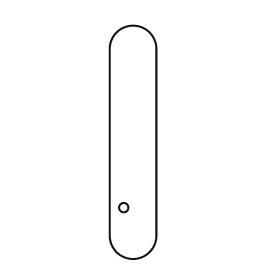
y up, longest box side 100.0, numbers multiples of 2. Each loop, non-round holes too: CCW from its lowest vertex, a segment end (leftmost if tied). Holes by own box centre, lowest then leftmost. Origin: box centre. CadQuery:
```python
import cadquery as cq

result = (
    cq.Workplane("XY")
    .moveTo(-10.0, -40.0)
    .threePointArc((0.0, -50.0), (10.0, -40.0))
    .lineTo(10.0, 40.0)
    .threePointArc((0.0, 50.0), (-10.0, 40.0))
    .close()
    .moveTo(-4.0, -28.0)
    .circle(2.0)
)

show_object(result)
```